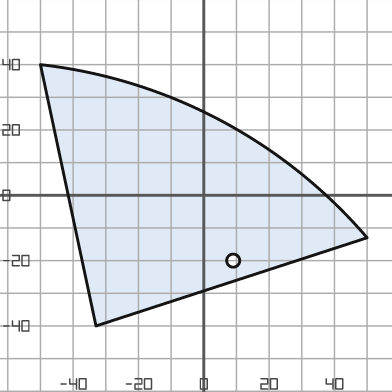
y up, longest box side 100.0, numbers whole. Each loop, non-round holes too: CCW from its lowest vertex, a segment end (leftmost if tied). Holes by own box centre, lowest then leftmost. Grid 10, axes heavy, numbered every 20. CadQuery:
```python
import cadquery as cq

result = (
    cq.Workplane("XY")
    .moveTo(-33.0, -40.0)
    .lineTo(50.0, -13.0)
    .threePointArc((5.0, 23.0), (-50.0, 40.0))
    .close()
    .moveTo(9.0, -20.0)
    .circle(2.0)
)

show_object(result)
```